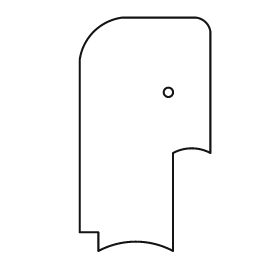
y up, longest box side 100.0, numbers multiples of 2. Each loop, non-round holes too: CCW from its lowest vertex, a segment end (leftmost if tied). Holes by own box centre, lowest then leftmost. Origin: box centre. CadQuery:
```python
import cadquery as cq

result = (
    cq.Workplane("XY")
    .moveTo(-20.0, -50.0)
    .threePointArc((-4.0, -46.0), (12.0, -50.0))
    .lineTo(12.0, -8.0)
    .threePointArc((20.0, -6.0), (28.0, -8.0))
    .lineTo(28.0, 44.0)
    .threePointArc((26.0, 48.0), (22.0, 50.0))
    .lineTo(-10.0, 50.0)
    .threePointArc((-22.0, 44.0), (-28.0, 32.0))
    .lineTo(-28.0, -42.0)
    .lineTo(-20.0, -42.0)
    .close()
    .moveTo(10.0, 18.0)
    .circle(2.0)
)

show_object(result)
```